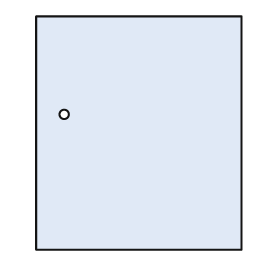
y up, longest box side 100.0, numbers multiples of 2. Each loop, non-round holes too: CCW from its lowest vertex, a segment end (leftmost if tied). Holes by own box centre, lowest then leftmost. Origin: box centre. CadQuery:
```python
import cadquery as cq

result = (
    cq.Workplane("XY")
    .moveTo(-44.0, -50.0)
    .lineTo(44.0, -50.0)
    .lineTo(44.0, 50.0)
    .lineTo(-44.0, 50.0)
    .close()
    .moveTo(-32.0, 8.0)
    .circle(2.0)
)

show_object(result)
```